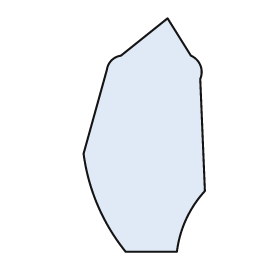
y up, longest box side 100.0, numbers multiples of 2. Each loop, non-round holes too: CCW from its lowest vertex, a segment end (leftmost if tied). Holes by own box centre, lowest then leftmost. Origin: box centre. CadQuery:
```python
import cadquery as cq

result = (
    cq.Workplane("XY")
    .moveTo(-8.0, -50.0)
    .lineTo(14.0, -50.0)
    .threePointArc((18.0, -36.0), (26.0, -24.0))
    .lineTo(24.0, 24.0)
    .threePointArc((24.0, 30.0), (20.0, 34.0))
    .lineTo(10.0, 50.0)
    .lineTo(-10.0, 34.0)
    .threePointArc((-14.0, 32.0), (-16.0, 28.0))
    .lineTo(-26.0, -8.0)
    .threePointArc((-20.0, -30.0), (-8.0, -50.0))
    .close()
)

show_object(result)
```